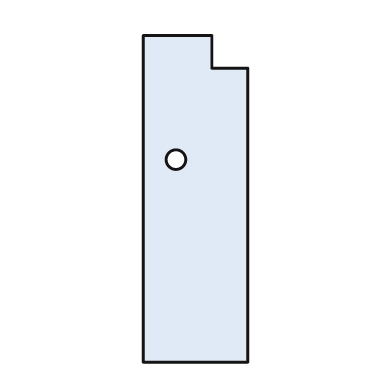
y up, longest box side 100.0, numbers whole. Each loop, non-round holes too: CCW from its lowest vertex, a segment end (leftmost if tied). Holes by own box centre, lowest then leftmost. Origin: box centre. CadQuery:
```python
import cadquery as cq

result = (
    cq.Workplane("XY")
    .moveTo(-16.0, -50.0)
    .lineTo(16.0, -50.0)
    .lineTo(16.0, 40.0)
    .lineTo(5.0, 40.0)
    .lineTo(5.0, 50.0)
    .lineTo(-16.0, 50.0)
    .close()
    .moveTo(-6.0, 12.0)
    .circle(3.0)
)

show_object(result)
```